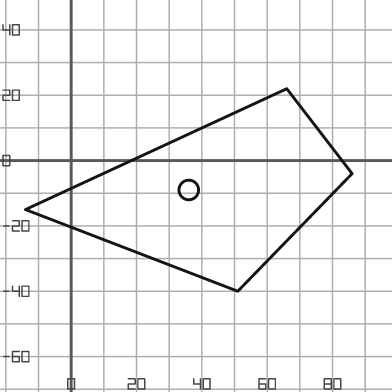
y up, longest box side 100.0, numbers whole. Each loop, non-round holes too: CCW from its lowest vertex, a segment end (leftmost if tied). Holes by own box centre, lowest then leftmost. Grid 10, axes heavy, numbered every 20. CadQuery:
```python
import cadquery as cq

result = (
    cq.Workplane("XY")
    .moveTo(51.0, -40.0)
    .lineTo(86.0, -4.0)
    .lineTo(66.0, 22.0)
    .lineTo(-14.0, -15.0)
    .close()
    .moveTo(36.0, -9.0)
    .circle(3.0)
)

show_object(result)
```